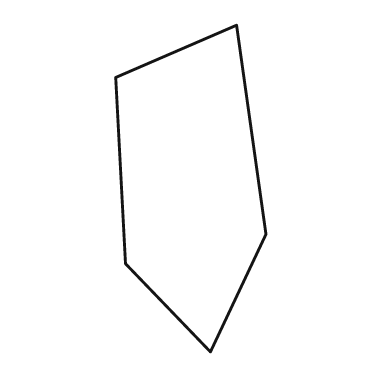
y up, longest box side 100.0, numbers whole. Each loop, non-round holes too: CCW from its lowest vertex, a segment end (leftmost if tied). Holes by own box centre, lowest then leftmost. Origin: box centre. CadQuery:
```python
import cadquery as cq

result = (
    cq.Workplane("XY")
    .moveTo(6.0, -50.0)
    .lineTo(23.0, -14.0)
    .lineTo(14.0, 50.0)
    .lineTo(-23.0, 34.0)
    .lineTo(-20.0, -23.0)
    .close()
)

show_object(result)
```